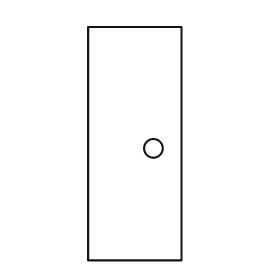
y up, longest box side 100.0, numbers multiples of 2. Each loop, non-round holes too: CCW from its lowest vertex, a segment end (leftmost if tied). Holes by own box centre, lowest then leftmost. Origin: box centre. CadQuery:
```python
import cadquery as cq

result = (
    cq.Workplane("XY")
    .moveTo(-20.0, -50.0)
    .lineTo(20.0, -50.0)
    .lineTo(20.0, 50.0)
    .lineTo(-20.0, 50.0)
    .close()
    .moveTo(8.0, -2.0)
    .circle(4.0)
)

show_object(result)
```